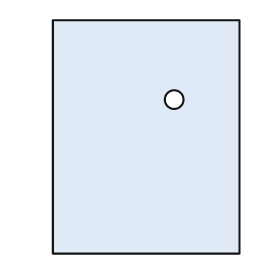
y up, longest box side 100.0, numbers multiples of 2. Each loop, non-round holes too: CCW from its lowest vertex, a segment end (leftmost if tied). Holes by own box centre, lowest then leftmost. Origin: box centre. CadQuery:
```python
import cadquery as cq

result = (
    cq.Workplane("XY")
    .moveTo(-40.0, -50.0)
    .lineTo(40.0, -50.0)
    .lineTo(40.0, 50.0)
    .lineTo(-40.0, 50.0)
    .close()
    .moveTo(12.0, 16.0)
    .circle(4.0)
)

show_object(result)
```